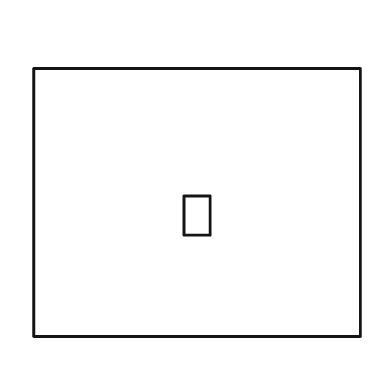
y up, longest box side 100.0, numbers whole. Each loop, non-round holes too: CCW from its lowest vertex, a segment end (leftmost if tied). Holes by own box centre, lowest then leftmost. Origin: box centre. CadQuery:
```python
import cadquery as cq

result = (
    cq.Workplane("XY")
    .moveTo(-50.0, -41.0)
    .lineTo(50.0, -41.0)
    .lineTo(50.0, 41.0)
    .lineTo(-50.0, 41.0)
    .close()
    .moveTo(-4.0, -10.0)
    .lineTo(4.0, -10.0)
    .lineTo(4.0, 2.0)
    .lineTo(-4.0, 2.0)
    .close()
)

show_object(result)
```